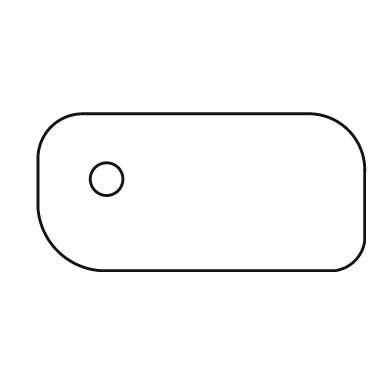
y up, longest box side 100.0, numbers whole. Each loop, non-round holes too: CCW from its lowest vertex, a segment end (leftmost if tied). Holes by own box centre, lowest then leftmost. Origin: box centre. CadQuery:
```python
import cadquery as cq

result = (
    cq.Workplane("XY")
    .moveTo(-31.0, -24.0)
    .lineTo(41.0, -24.0)
    .threePointArc((47.0, -21.0), (50.0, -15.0))
    .lineTo(50.0, 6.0)
    .threePointArc((45.0, 19.0), (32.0, 24.0))
    .lineTo(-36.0, 24.0)
    .threePointArc((-46.0, 20.0), (-50.0, 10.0))
    .lineTo(-50.0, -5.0)
    .threePointArc((-44.0, -18.0), (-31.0, -24.0))
    .close()
    .moveTo(-29.0, 4.0)
    .circle(5.0)
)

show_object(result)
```